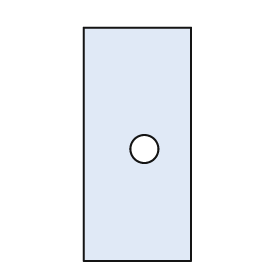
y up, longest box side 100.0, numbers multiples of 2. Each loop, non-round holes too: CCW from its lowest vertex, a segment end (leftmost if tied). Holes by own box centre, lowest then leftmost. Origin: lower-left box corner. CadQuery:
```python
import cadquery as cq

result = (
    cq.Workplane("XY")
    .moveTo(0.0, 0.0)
    .lineTo(46.0, 0.0)
    .lineTo(46.0, 100.0)
    .lineTo(0.0, 100.0)
    .close()
    .moveTo(26.0, 48.0)
    .circle(6.0)
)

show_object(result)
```